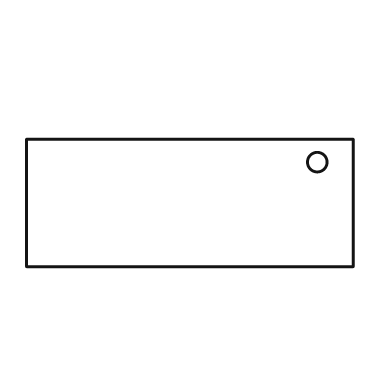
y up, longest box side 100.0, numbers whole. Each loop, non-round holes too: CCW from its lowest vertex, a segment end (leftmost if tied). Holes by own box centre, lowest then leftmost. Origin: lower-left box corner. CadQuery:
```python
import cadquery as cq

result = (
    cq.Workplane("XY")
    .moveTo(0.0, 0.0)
    .lineTo(100.0, 0.0)
    .lineTo(100.0, 39.0)
    .lineTo(0.0, 39.0)
    .close()
    .moveTo(89.0, 32.0)
    .circle(3.0)
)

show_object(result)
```